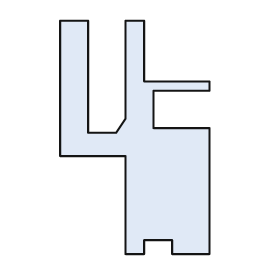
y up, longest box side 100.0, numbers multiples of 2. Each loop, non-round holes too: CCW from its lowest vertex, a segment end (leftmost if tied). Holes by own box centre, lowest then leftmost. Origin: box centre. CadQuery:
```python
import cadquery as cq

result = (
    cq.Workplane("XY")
    .moveTo(-4.0, -50.0)
    .lineTo(4.0, -50.0)
    .lineTo(4.0, -44.0)
    .lineTo(16.0, -44.0)
    .lineTo(16.0, -50.0)
    .lineTo(32.0, -50.0)
    .lineTo(32.0, 4.0)
    .lineTo(8.0, 4.0)
    .lineTo(8.0, 20.0)
    .lineTo(32.0, 20.0)
    .lineTo(32.0, 24.0)
    .lineTo(4.0, 24.0)
    .lineTo(4.0, 50.0)
    .lineTo(-4.0, 50.0)
    .lineTo(-4.0, 8.0)
    .lineTo(-8.0, 2.0)
    .lineTo(-20.0, 2.0)
    .lineTo(-20.0, 50.0)
    .lineTo(-32.0, 50.0)
    .lineTo(-32.0, -8.0)
    .lineTo(-4.0, -8.0)
    .close()
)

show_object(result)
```